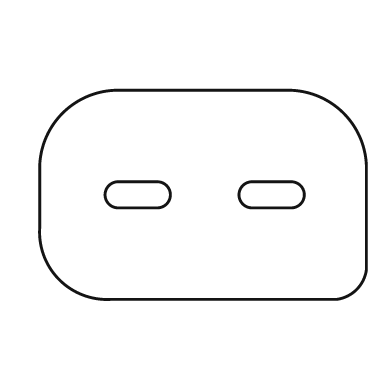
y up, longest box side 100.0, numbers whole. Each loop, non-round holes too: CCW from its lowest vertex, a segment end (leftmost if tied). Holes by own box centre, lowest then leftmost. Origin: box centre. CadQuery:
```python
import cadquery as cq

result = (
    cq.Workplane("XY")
    .moveTo(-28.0, -32.0)
    .lineTo(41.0, -32.0)
    .threePointArc((47.0, -29.0), (50.0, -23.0))
    .lineTo(50.0, 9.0)
    .threePointArc((43.0, 25.0), (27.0, 32.0))
    .lineTo(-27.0, 32.0)
    .threePointArc((-43.0, 25.0), (-50.0, 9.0))
    .lineTo(-50.0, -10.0)
    .threePointArc((-44.0, -26.0), (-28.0, -32.0))
    .close()
    .moveTo(-26.0, -4.0)
    .lineTo(-14.0, -4.0)
    .threePointArc((-10.0, 0.0), (-14.0, 4.0))
    .lineTo(-26.0, 4.0)
    .threePointArc((-30.0, 0.0), (-26.0, -4.0))
    .close()
    .moveTo(15.0, -4.0)
    .lineTo(27.0, -4.0)
    .threePointArc((31.0, 0.0), (27.0, 4.0))
    .lineTo(15.0, 4.0)
    .threePointArc((11.0, 0.0), (15.0, -4.0))
    .close()
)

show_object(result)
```